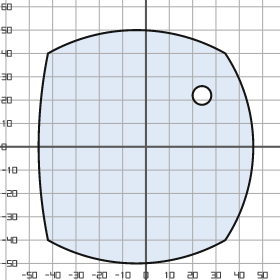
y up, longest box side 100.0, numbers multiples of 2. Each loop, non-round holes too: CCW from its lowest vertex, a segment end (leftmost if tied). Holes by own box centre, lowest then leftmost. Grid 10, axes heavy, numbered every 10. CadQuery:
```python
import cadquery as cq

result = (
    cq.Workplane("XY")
    .moveTo(-42.0, -40.0)
    .threePointArc((-4.0, -50.0), (34.0, -40.0))
    .threePointArc((46.0, 0.0), (34.0, 40.0))
    .threePointArc((-4.0, 50.0), (-42.0, 40.0))
    .threePointArc((-46.0, 0.0), (-42.0, -40.0))
    .close()
    .moveTo(24.0, 22.0)
    .circle(4.0)
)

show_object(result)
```